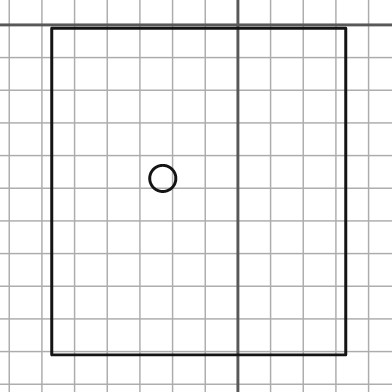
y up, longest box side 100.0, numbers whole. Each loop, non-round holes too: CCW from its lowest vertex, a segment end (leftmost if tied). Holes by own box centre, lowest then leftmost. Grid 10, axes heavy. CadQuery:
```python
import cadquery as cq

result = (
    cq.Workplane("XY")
    .moveTo(-57.0, -101.0)
    .lineTo(33.0, -101.0)
    .lineTo(33.0, -1.0)
    .lineTo(-57.0, -1.0)
    .close()
    .moveTo(-23.0, -47.0)
    .circle(4.0)
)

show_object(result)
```